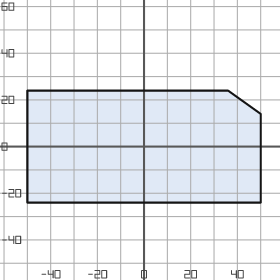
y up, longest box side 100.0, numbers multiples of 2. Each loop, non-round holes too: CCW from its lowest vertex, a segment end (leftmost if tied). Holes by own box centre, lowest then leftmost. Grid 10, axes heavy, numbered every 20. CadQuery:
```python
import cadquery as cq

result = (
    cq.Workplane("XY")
    .moveTo(-50.0, -24.0)
    .lineTo(50.0, -24.0)
    .lineTo(50.0, 14.0)
    .lineTo(36.0, 24.0)
    .lineTo(-50.0, 24.0)
    .close()
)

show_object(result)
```